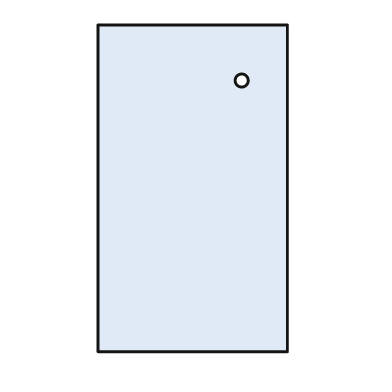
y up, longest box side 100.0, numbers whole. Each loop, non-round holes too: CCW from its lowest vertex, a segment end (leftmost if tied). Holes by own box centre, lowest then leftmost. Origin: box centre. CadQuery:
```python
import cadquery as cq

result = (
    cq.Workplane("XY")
    .moveTo(-29.0, -50.0)
    .lineTo(29.0, -50.0)
    .lineTo(29.0, 50.0)
    .lineTo(-29.0, 50.0)
    .close()
    .moveTo(15.0, 33.0)
    .circle(2.0)
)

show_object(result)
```